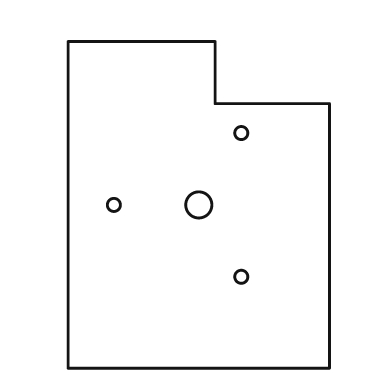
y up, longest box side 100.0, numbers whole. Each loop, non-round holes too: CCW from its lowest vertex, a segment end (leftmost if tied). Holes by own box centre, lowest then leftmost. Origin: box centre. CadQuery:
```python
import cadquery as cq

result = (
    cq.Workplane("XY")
    .moveTo(-40.0, -50.0)
    .lineTo(40.0, -50.0)
    .lineTo(40.0, 31.0)
    .lineTo(5.0, 31.0)
    .lineTo(5.0, 50.0)
    .lineTo(-40.0, 50.0)
    .close()
    .moveTo(13.0, -22.0)
    .circle(2.0)
    .moveTo(-26.0, 0.0)
    .circle(2.0)
    .moveTo(0.0, 0.0)
    .circle(4.0)
    .moveTo(13.0, 22.0)
    .circle(2.0)
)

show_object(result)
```